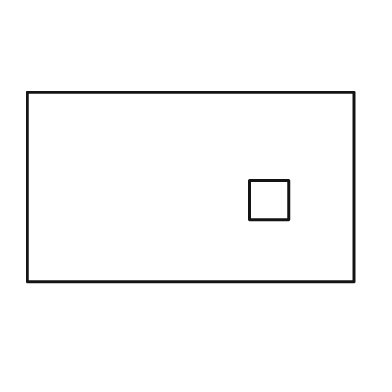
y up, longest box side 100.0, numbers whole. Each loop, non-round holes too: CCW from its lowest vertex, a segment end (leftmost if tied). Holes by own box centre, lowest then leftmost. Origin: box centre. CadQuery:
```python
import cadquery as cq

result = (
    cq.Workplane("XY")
    .moveTo(-50.0, -29.0)
    .lineTo(50.0, -29.0)
    .lineTo(50.0, 29.0)
    .lineTo(-50.0, 29.0)
    .close()
    .moveTo(18.0, -10.0)
    .lineTo(30.0, -10.0)
    .lineTo(30.0, 2.0)
    .lineTo(18.0, 2.0)
    .close()
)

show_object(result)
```